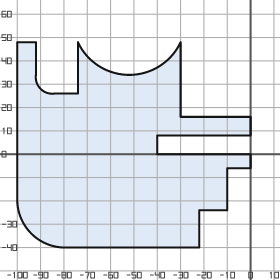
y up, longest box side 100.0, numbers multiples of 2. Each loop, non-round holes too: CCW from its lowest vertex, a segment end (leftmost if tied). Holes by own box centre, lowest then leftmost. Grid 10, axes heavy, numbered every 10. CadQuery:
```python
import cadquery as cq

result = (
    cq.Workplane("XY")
    .moveTo(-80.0, -40.0)
    .lineTo(-22.0, -40.0)
    .lineTo(-22.0, -24.0)
    .lineTo(-10.0, -24.0)
    .lineTo(-10.0, -6.0)
    .lineTo(0.0, -6.0)
    .lineTo(0.0, 0.0)
    .lineTo(-40.0, 0.0)
    .lineTo(-40.0, 8.0)
    .lineTo(0.0, 8.0)
    .lineTo(0.0, 16.0)
    .lineTo(-30.0, 16.0)
    .lineTo(-30.0, 48.0)
    .threePointArc((-52.0, 34.0), (-74.0, 48.0))
    .lineTo(-74.0, 26.0)
    .lineTo(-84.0, 26.0)
    .threePointArc((-90.0, 28.0), (-92.0, 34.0))
    .lineTo(-92.0, 48.0)
    .lineTo(-100.0, 48.0)
    .lineTo(-100.0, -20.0)
    .threePointArc((-94.0, -34.0), (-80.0, -40.0))
    .close()
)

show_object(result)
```